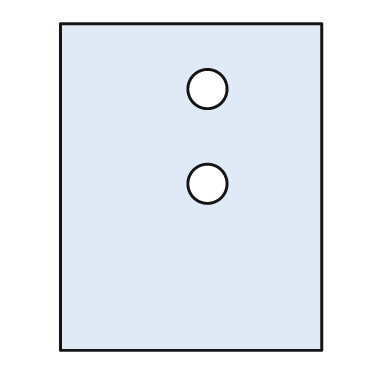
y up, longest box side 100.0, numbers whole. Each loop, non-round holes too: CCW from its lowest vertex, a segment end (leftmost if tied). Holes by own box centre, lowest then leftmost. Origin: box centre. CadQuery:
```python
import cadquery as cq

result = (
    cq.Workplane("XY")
    .moveTo(-40.0, -50.0)
    .lineTo(40.0, -50.0)
    .lineTo(40.0, 50.0)
    .lineTo(-40.0, 50.0)
    .close()
    .moveTo(5.0, 1.0)
    .circle(6.0)
    .moveTo(5.0, 30.0)
    .circle(6.0)
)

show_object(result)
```